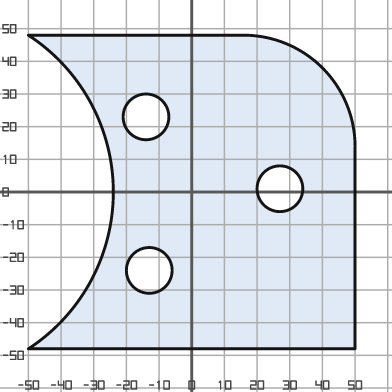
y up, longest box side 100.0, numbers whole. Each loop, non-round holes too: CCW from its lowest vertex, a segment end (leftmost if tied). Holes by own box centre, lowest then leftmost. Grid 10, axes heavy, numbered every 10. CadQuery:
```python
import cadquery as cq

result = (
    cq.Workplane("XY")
    .moveTo(-50.0, -48.0)
    .lineTo(50.0, -48.0)
    .lineTo(50.0, 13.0)
    .threePointArc((40.0, 38.0), (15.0, 48.0))
    .lineTo(-50.0, 48.0)
    .threePointArc((-24.0, 0.0), (-50.0, -48.0))
    .close()
    .moveTo(-13.0, -24.0)
    .circle(7.0)
    .moveTo(27.0, 1.0)
    .circle(7.0)
    .moveTo(-14.0, 23.0)
    .circle(7.0)
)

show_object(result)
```